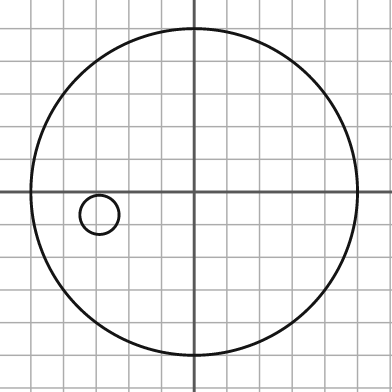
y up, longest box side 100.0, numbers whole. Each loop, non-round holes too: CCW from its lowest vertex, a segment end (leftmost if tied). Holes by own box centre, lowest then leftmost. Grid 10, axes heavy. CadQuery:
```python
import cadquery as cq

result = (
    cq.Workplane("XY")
    .moveTo(0.0, 0.0)
    .circle(50.0)
    .moveTo(-29.0, -7.0)
    .circle(6.0)
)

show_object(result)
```